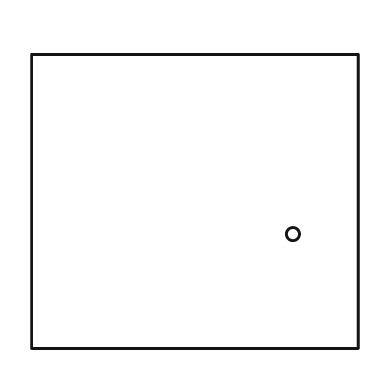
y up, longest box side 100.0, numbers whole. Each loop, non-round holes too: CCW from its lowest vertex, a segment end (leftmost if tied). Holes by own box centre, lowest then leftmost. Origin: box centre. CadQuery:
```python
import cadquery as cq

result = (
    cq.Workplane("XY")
    .moveTo(-50.0, -45.0)
    .lineTo(50.0, -45.0)
    .lineTo(50.0, 45.0)
    .lineTo(-50.0, 45.0)
    .close()
    .moveTo(30.0, -10.0)
    .circle(2.0)
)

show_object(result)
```